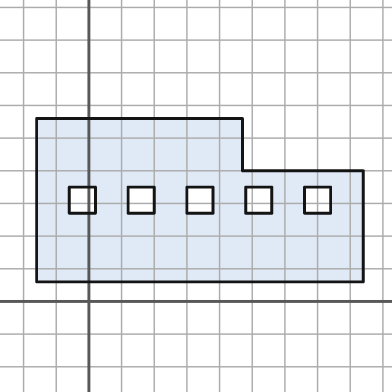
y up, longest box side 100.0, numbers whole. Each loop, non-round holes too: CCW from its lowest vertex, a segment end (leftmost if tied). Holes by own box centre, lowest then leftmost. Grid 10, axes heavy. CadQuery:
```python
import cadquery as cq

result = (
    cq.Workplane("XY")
    .moveTo(-16.0, 6.0)
    .lineTo(84.0, 6.0)
    .lineTo(84.0, 40.0)
    .lineTo(47.0, 40.0)
    .lineTo(47.0, 56.0)
    .lineTo(-16.0, 56.0)
    .close()
    .moveTo(-6.0, 27.0)
    .lineTo(2.0, 27.0)
    .lineTo(2.0, 35.0)
    .lineTo(-6.0, 35.0)
    .close()
    .moveTo(12.0, 27.0)
    .lineTo(20.0, 27.0)
    .lineTo(20.0, 35.0)
    .lineTo(12.0, 35.0)
    .close()
    .moveTo(30.0, 27.0)
    .lineTo(38.0, 27.0)
    .lineTo(38.0, 35.0)
    .lineTo(30.0, 35.0)
    .close()
    .moveTo(48.0, 27.0)
    .lineTo(56.0, 27.0)
    .lineTo(56.0, 35.0)
    .lineTo(48.0, 35.0)
    .close()
    .moveTo(66.0, 27.0)
    .lineTo(74.0, 27.0)
    .lineTo(74.0, 35.0)
    .lineTo(66.0, 35.0)
    .close()
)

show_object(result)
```